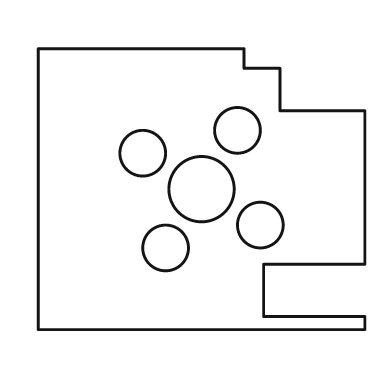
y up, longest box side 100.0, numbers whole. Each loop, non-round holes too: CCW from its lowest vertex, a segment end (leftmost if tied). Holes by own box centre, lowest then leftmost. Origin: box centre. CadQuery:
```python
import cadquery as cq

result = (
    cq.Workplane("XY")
    .moveTo(-50.0, -43.0)
    .lineTo(50.0, -43.0)
    .lineTo(50.0, -39.0)
    .lineTo(19.0, -39.0)
    .lineTo(19.0, -23.0)
    .lineTo(50.0, -23.0)
    .lineTo(50.0, 24.0)
    .lineTo(24.0, 24.0)
    .lineTo(24.0, 37.0)
    .lineTo(13.0, 37.0)
    .lineTo(13.0, 43.0)
    .lineTo(-50.0, 43.0)
    .close()
    .moveTo(-11.0, -18.0)
    .circle(7.0)
    .moveTo(18.0, -11.0)
    .circle(7.0)
    .moveTo(0.0, 0.0)
    .circle(10.0)
    .moveTo(-18.0, 11.0)
    .circle(7.0)
    .moveTo(11.0, 18.0)
    .circle(7.0)
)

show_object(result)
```